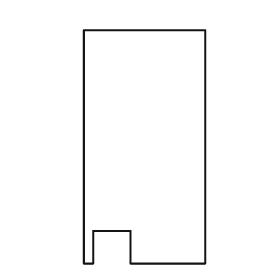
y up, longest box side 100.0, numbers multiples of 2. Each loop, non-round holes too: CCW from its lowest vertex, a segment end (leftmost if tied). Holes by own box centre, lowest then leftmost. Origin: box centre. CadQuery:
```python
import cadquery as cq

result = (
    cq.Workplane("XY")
    .moveTo(-26.0, -50.0)
    .lineTo(-22.0, -50.0)
    .lineTo(-22.0, -36.0)
    .lineTo(-6.0, -36.0)
    .lineTo(-6.0, -50.0)
    .lineTo(26.0, -50.0)
    .lineTo(26.0, 50.0)
    .lineTo(-26.0, 50.0)
    .close()
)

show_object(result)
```